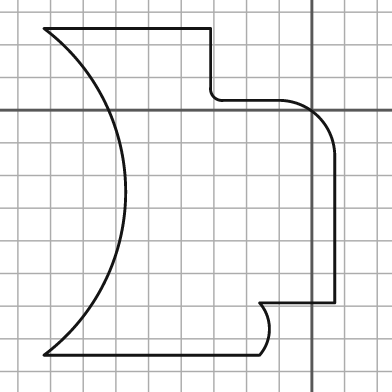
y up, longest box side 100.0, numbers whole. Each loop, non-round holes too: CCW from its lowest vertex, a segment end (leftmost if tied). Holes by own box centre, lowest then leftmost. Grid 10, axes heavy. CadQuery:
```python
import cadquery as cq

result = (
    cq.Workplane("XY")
    .moveTo(-82.0, -75.0)
    .lineTo(-16.0, -75.0)
    .threePointArc((-13.0, -67.0), (-16.0, -59.0))
    .lineTo(7.0, -59.0)
    .lineTo(7.0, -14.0)
    .threePointArc((2.0, -2.0), (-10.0, 3.0))
    .lineTo(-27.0, 3.0)
    .threePointArc((-30.0, 4.0), (-31.0, 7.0))
    .lineTo(-31.0, 25.0)
    .lineTo(-82.0, 25.0)
    .threePointArc((-57.0, -25.0), (-82.0, -75.0))
    .close()
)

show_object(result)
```